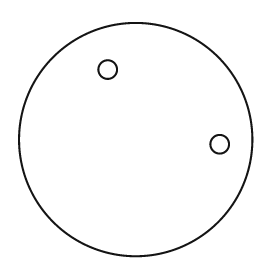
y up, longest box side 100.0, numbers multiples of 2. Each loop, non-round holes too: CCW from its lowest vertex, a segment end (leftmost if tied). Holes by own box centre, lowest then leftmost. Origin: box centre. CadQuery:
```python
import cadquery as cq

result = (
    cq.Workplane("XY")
    .moveTo(0.0, 0.0)
    .circle(50.0)
    .moveTo(36.0, -2.0)
    .circle(4.0)
    .moveTo(-12.0, 30.0)
    .circle(4.0)
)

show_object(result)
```